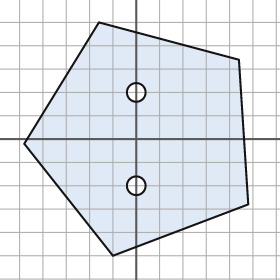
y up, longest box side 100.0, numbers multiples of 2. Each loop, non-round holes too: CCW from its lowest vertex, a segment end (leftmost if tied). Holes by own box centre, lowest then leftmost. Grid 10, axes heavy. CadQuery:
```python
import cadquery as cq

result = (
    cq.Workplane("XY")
    .moveTo(-10.0, -50.0)
    .lineTo(48.0, -28.0)
    .lineTo(44.0, 34.0)
    .lineTo(-16.0, 50.0)
    .lineTo(-48.0, -2.0)
    .close()
    .moveTo(0.0, -20.0)
    .circle(4.0)
    .moveTo(0.0, 20.0)
    .circle(4.0)
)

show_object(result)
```